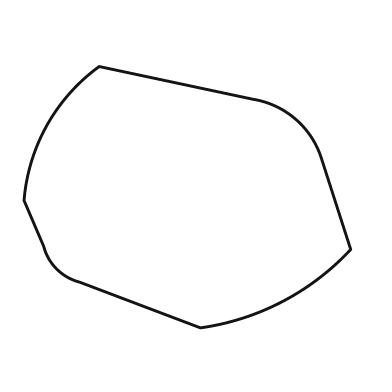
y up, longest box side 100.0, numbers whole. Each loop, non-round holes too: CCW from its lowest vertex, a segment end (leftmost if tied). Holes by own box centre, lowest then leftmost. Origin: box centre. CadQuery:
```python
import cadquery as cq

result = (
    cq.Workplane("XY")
    .moveTo(4.0, -40.0)
    .threePointArc((29.0, -32.0), (50.0, -16.0))
    .lineTo(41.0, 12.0)
    .threePointArc((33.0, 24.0), (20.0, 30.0))
    .lineTo(-27.0, 40.0)
    .threePointArc((-43.0, 22.0), (-50.0, -1.0))
    .lineTo(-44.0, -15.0)
    .threePointArc((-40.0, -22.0), (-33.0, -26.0))
    .close()
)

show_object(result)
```